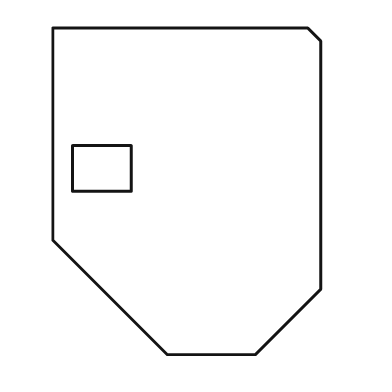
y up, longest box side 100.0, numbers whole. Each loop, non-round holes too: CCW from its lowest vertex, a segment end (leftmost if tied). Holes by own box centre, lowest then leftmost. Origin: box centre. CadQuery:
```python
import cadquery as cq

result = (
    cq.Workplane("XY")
    .moveTo(-6.0, -50.0)
    .lineTo(21.0, -50.0)
    .lineTo(41.0, -30.0)
    .lineTo(41.0, 46.0)
    .lineTo(37.0, 50.0)
    .lineTo(-41.0, 50.0)
    .lineTo(-41.0, -15.0)
    .close()
    .moveTo(-35.0, 0.0)
    .lineTo(-17.0, 0.0)
    .lineTo(-17.0, 14.0)
    .lineTo(-35.0, 14.0)
    .close()
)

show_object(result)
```